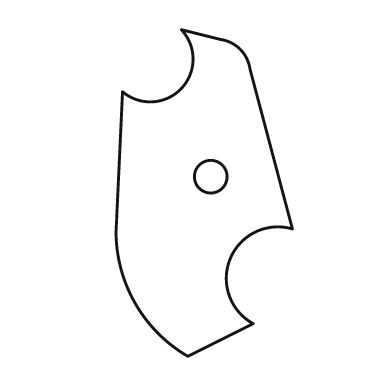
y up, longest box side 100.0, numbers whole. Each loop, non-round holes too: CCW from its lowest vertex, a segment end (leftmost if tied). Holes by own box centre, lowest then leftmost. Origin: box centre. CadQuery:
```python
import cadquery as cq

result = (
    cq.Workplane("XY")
    .moveTo(-5.0, -50.0)
    .lineTo(15.0, -40.0)
    .threePointArc((8.0, -20.0), (27.0, -11.0))
    .lineTo(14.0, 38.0)
    .threePointArc((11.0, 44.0), (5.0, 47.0))
    .lineTo(-7.0, 50.0)
    .threePointArc((-7.0, 32.0), (-25.0, 31.0))
    .lineTo(-27.0, -12.0)
    .threePointArc((-21.0, -34.0), (-5.0, -50.0))
    .close()
    .moveTo(2.0, 5.0)
    .circle(5.0)
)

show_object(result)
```